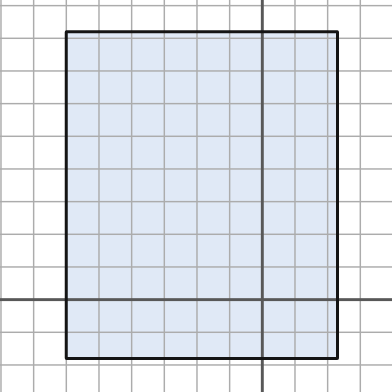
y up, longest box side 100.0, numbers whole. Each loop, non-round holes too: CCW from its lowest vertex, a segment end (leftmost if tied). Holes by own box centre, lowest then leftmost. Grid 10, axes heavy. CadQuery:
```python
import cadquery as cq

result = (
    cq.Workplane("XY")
    .moveTo(-60.0, -18.0)
    .lineTo(23.0, -18.0)
    .lineTo(23.0, 82.0)
    .lineTo(-60.0, 82.0)
    .close()
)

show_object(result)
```